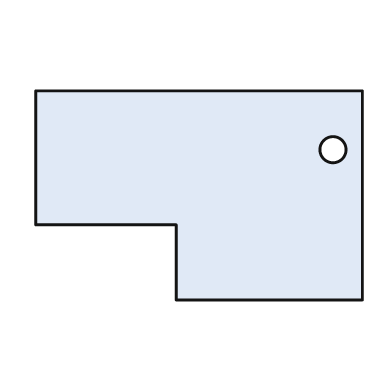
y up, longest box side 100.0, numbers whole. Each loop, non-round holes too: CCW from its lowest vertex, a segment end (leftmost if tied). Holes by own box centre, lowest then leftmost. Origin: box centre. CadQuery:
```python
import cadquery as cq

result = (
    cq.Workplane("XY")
    .moveTo(-7.0, -32.0)
    .lineTo(50.0, -32.0)
    .lineTo(50.0, 32.0)
    .lineTo(-50.0, 32.0)
    .lineTo(-50.0, -9.0)
    .lineTo(-7.0, -9.0)
    .close()
    .moveTo(41.0, 14.0)
    .circle(4.0)
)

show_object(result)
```